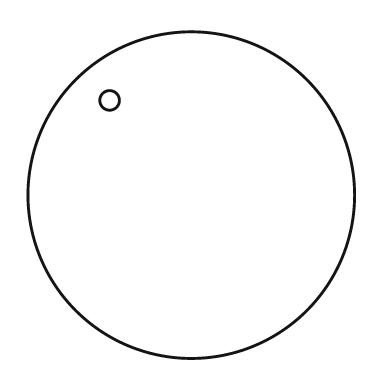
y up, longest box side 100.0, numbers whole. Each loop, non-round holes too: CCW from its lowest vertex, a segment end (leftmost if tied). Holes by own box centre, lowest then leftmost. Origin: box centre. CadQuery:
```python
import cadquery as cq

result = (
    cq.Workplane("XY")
    .moveTo(0.0, 0.0)
    .circle(50.0)
    .moveTo(-25.0, 29.0)
    .circle(3.0)
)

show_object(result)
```